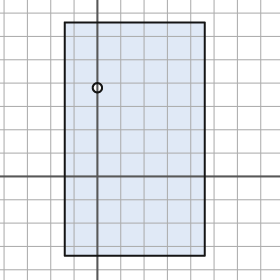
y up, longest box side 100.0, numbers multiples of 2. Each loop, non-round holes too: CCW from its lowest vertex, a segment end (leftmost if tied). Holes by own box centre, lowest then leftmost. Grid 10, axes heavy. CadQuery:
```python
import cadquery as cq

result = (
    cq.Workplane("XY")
    .moveTo(-14.0, -34.0)
    .lineTo(46.0, -34.0)
    .lineTo(46.0, 66.0)
    .lineTo(-14.0, 66.0)
    .close()
    .moveTo(0.0, 38.0)
    .circle(2.0)
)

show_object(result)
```